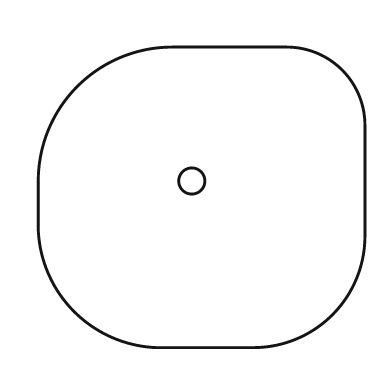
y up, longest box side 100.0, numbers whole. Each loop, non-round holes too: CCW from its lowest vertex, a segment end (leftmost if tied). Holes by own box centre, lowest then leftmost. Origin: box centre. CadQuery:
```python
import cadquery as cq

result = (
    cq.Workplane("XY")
    .moveTo(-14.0, -46.0)
    .lineTo(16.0, -46.0)
    .threePointArc((40.0, -36.0), (50.0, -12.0))
    .lineTo(50.0, 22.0)
    .threePointArc((43.0, 39.0), (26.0, 46.0))
    .lineTo(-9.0, 46.0)
    .threePointArc((-38.0, 34.0), (-50.0, 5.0))
    .lineTo(-50.0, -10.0)
    .threePointArc((-39.0, -35.0), (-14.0, -46.0))
    .close()
    .moveTo(-3.0, 5.0)
    .circle(4.0)
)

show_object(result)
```